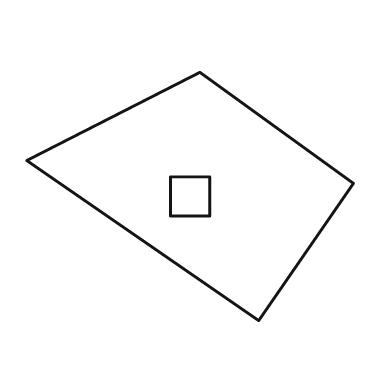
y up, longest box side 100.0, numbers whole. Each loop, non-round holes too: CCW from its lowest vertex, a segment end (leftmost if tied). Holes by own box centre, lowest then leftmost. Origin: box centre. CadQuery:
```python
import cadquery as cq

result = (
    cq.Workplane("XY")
    .moveTo(21.0, -38.0)
    .lineTo(50.0, 4.0)
    .lineTo(3.0, 38.0)
    .lineTo(-50.0, 11.0)
    .close()
    .moveTo(-6.0, -6.0)
    .lineTo(6.0, -6.0)
    .lineTo(6.0, 6.0)
    .lineTo(-6.0, 6.0)
    .close()
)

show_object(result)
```